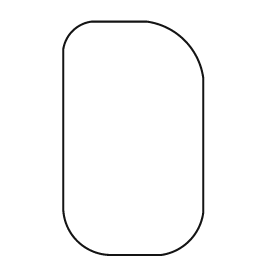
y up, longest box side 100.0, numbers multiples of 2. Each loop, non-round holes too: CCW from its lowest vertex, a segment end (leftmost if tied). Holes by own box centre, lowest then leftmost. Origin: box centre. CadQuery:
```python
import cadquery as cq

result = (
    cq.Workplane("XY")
    .moveTo(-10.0, -50.0)
    .lineTo(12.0, -50.0)
    .threePointArc((24.0, -44.0), (30.0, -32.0))
    .lineTo(30.0, 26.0)
    .threePointArc((22.0, 42.0), (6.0, 50.0))
    .lineTo(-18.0, 50.0)
    .threePointArc((-26.0, 46.0), (-30.0, 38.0))
    .lineTo(-30.0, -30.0)
    .threePointArc((-24.0, -44.0), (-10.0, -50.0))
    .close()
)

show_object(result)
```